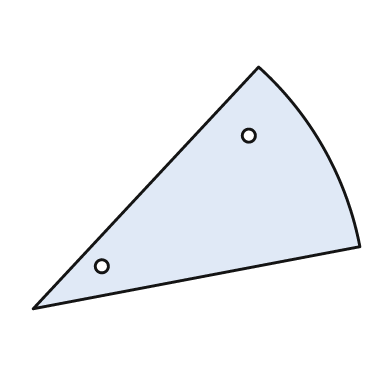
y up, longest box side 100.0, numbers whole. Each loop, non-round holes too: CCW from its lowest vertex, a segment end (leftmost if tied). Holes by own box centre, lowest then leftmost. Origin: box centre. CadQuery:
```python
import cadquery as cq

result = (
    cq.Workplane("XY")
    .moveTo(-50.0, -37.0)
    .lineTo(50.0, -18.0)
    .threePointArc((39.0, 12.0), (19.0, 37.0))
    .close()
    .moveTo(-29.0, -24.0)
    .circle(2.0)
    .moveTo(16.0, 16.0)
    .circle(2.0)
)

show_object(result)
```